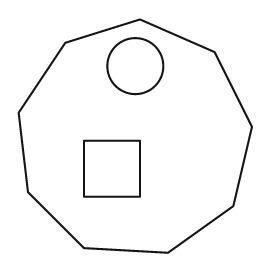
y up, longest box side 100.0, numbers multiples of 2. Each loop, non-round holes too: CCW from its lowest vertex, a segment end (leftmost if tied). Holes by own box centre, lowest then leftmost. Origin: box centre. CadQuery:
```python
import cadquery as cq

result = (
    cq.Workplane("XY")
    .moveTo(14.0, -50.0)
    .lineTo(42.0, -30.0)
    .lineTo(50.0, 4.0)
    .lineTo(34.0, 36.0)
    .lineTo(2.0, 50.0)
    .lineTo(-30.0, 40.0)
    .lineTo(-50.0, 10.0)
    .lineTo(-46.0, -24.0)
    .lineTo(-22.0, -48.0)
    .close()
    .moveTo(-22.0, -26.0)
    .lineTo(2.0, -26.0)
    .lineTo(2.0, -2.0)
    .lineTo(-22.0, -2.0)
    .close()
    .moveTo(0.0, 30.0)
    .circle(12.0)
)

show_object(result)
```